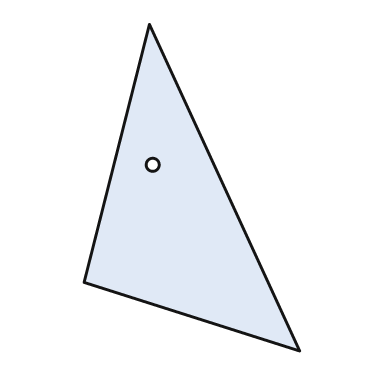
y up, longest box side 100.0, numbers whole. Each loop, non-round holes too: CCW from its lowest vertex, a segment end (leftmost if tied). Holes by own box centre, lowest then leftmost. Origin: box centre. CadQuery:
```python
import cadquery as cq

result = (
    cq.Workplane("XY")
    .moveTo(33.0, -50.0)
    .lineTo(-13.0, 50.0)
    .lineTo(-33.0, -29.0)
    .close()
    .moveTo(-12.0, 7.0)
    .circle(2.0)
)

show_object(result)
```